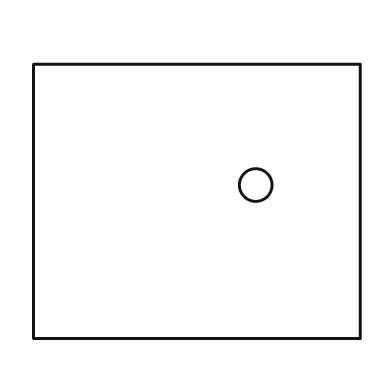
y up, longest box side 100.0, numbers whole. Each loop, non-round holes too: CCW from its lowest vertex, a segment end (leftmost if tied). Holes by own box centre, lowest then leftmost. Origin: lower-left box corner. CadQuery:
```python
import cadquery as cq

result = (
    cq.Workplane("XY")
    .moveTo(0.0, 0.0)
    .lineTo(100.0, 0.0)
    .lineTo(100.0, 84.0)
    .lineTo(0.0, 84.0)
    .close()
    .moveTo(68.0, 47.0)
    .circle(5.0)
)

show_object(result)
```